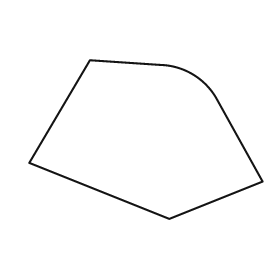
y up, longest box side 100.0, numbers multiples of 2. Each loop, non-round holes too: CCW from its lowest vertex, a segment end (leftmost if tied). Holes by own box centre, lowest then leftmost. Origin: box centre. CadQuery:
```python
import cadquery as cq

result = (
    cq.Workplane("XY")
    .moveTo(10.0, -34.0)
    .lineTo(50.0, -18.0)
    .lineTo(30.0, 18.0)
    .threePointArc((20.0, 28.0), (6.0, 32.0))
    .lineTo(-24.0, 34.0)
    .lineTo(-50.0, -10.0)
    .close()
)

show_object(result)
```